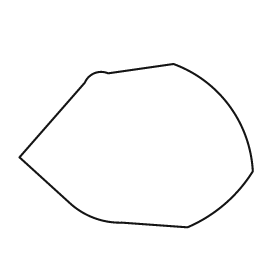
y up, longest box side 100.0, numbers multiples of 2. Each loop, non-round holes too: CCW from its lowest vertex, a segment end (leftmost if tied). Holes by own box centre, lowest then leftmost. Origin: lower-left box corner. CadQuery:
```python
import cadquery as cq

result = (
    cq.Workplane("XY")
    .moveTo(72.0, 0.0)
    .threePointArc((88.0, 10.0), (100.0, 24.0))
    .threePointArc((90.0, 52.0), (66.0, 70.0))
    .lineTo(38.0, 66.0)
    .threePointArc((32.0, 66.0), (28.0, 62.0))
    .lineTo(0.0, 30.0)
    .lineTo(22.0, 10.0)
    .threePointArc((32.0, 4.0), (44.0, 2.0))
    .close()
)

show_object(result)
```